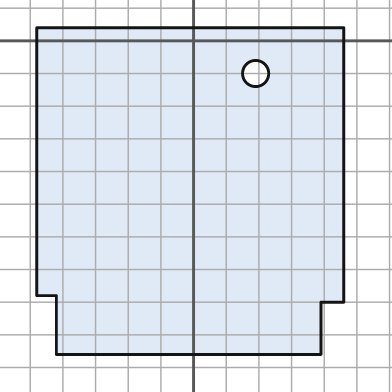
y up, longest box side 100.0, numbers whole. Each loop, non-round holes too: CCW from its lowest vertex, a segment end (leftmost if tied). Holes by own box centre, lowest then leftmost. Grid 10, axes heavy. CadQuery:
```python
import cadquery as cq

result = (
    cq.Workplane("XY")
    .moveTo(-42.0, -96.0)
    .lineTo(39.0, -96.0)
    .lineTo(39.0, -80.0)
    .lineTo(46.0, -80.0)
    .lineTo(46.0, 4.0)
    .lineTo(-48.0, 4.0)
    .lineTo(-48.0, -78.0)
    .lineTo(-42.0, -78.0)
    .close()
    .moveTo(19.0, -10.0)
    .circle(4.0)
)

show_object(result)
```